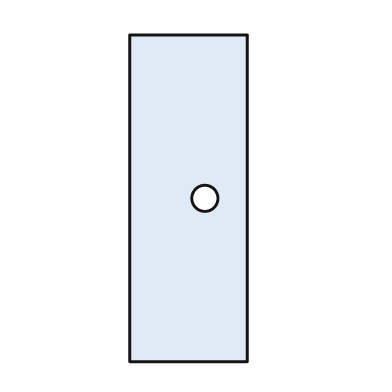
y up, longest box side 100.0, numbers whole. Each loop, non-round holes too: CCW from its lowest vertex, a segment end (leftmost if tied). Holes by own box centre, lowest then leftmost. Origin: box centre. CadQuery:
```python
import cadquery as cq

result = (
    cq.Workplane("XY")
    .moveTo(-18.0, -50.0)
    .lineTo(18.0, -50.0)
    .lineTo(18.0, 50.0)
    .lineTo(-18.0, 50.0)
    .close()
    .moveTo(5.0, 0.0)
    .circle(4.0)
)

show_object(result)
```